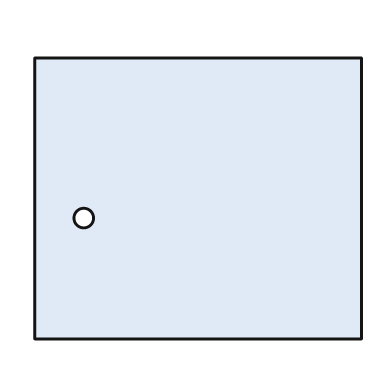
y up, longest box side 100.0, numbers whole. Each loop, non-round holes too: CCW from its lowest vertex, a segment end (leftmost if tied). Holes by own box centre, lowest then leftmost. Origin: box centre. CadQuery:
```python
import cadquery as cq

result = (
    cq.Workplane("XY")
    .moveTo(-50.0, -43.0)
    .lineTo(50.0, -43.0)
    .lineTo(50.0, 43.0)
    .lineTo(-50.0, 43.0)
    .close()
    .moveTo(-35.0, -6.0)
    .circle(3.0)
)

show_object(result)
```